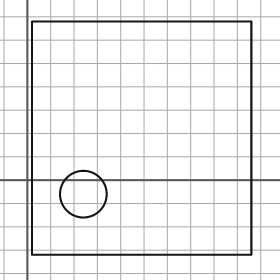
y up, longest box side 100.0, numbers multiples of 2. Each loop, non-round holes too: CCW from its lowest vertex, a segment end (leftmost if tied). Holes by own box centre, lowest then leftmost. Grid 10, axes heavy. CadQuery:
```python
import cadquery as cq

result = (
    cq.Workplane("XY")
    .moveTo(2.0, -32.0)
    .lineTo(96.0, -32.0)
    .lineTo(96.0, 68.0)
    .lineTo(2.0, 68.0)
    .close()
    .moveTo(24.0, -6.0)
    .circle(10.0)
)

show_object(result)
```